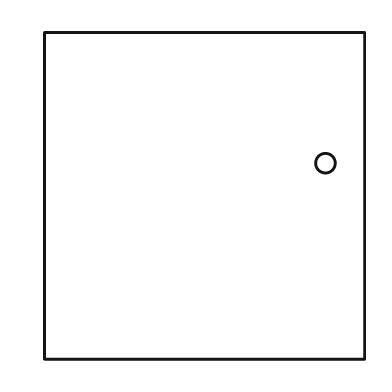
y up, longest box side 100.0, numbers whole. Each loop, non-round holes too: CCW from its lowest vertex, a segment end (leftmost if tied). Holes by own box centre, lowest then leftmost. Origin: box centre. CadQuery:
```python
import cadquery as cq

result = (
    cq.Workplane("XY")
    .moveTo(-49.0, -50.0)
    .lineTo(49.0, -50.0)
    .lineTo(49.0, 50.0)
    .lineTo(-49.0, 50.0)
    .close()
    .moveTo(37.0, 10.0)
    .circle(3.0)
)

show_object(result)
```